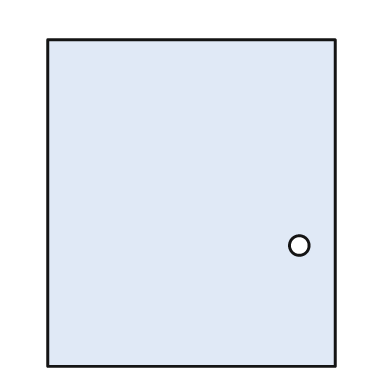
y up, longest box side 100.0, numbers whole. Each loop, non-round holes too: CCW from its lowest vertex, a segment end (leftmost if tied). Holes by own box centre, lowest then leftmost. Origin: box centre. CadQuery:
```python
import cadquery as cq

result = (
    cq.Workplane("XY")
    .moveTo(-44.0, -50.0)
    .lineTo(44.0, -50.0)
    .lineTo(44.0, 50.0)
    .lineTo(-44.0, 50.0)
    .close()
    .moveTo(33.0, -13.0)
    .circle(3.0)
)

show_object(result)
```